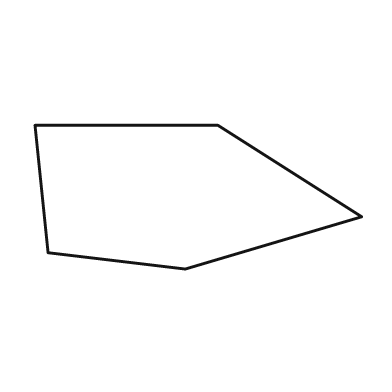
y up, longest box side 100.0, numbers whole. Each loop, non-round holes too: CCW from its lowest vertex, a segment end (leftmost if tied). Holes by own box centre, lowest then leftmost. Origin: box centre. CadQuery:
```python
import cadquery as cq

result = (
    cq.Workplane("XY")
    .moveTo(-4.0, -22.0)
    .lineTo(50.0, -6.0)
    .lineTo(6.0, 22.0)
    .lineTo(-50.0, 22.0)
    .lineTo(-46.0, -17.0)
    .close()
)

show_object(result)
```